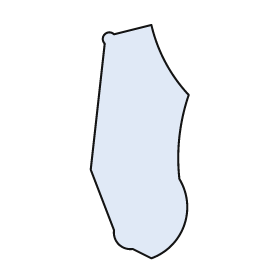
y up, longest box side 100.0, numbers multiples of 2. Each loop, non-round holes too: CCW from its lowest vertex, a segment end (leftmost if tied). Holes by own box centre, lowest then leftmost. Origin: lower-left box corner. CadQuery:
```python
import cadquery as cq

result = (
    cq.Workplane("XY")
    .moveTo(26.0, 0.0)
    .threePointArc((40.0, 14.0), (38.0, 34.0))
    .threePointArc((38.0, 52.0), (42.0, 70.0))
    .threePointArc((32.0, 84.0), (26.0, 100.0))
    .lineTo(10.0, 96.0)
    .threePointArc((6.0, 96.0), (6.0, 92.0))
    .lineTo(0.0, 38.0)
    .lineTo(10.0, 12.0)
    .threePointArc((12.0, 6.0), (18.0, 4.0))
    .close()
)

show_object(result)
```